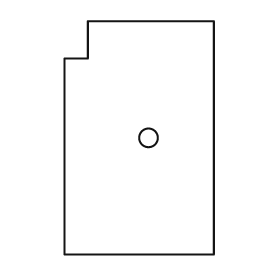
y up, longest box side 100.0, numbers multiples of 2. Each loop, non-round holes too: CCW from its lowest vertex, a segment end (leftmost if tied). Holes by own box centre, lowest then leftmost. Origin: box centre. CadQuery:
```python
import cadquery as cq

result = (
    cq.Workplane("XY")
    .moveTo(-32.0, -50.0)
    .lineTo(32.0, -50.0)
    .lineTo(32.0, 50.0)
    .lineTo(-22.0, 50.0)
    .lineTo(-22.0, 34.0)
    .lineTo(-32.0, 34.0)
    .close()
    .moveTo(4.0, 0.0)
    .circle(4.0)
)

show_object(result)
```